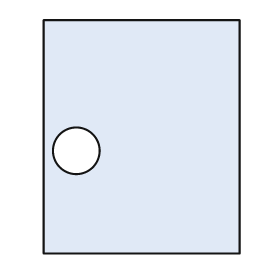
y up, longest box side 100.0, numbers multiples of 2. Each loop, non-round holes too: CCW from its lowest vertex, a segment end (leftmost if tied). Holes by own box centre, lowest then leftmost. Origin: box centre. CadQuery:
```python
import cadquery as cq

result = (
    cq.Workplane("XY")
    .moveTo(-42.0, -50.0)
    .lineTo(42.0, -50.0)
    .lineTo(42.0, 50.0)
    .lineTo(-42.0, 50.0)
    .close()
    .moveTo(-28.0, -6.0)
    .circle(10.0)
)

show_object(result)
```